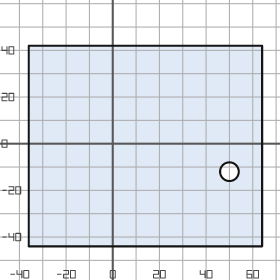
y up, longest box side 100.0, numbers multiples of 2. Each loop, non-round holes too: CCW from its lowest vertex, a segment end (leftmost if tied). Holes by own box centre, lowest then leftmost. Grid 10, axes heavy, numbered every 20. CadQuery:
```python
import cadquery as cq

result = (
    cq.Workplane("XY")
    .moveTo(-36.0, -44.0)
    .lineTo(64.0, -44.0)
    .lineTo(64.0, 42.0)
    .lineTo(-36.0, 42.0)
    .close()
    .moveTo(50.0, -12.0)
    .circle(4.0)
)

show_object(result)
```